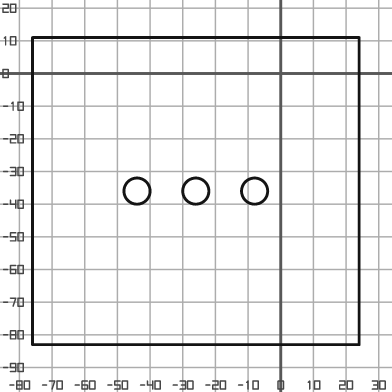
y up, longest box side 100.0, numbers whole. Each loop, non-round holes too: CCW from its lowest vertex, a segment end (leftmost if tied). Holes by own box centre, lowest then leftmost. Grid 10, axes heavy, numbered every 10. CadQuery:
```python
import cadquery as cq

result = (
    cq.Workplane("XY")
    .moveTo(-76.0, -83.0)
    .lineTo(24.0, -83.0)
    .lineTo(24.0, 11.0)
    .lineTo(-76.0, 11.0)
    .close()
    .moveTo(-44.0, -36.0)
    .circle(4.0)
    .moveTo(-26.0, -36.0)
    .circle(4.0)
    .moveTo(-8.0, -36.0)
    .circle(4.0)
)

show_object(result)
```